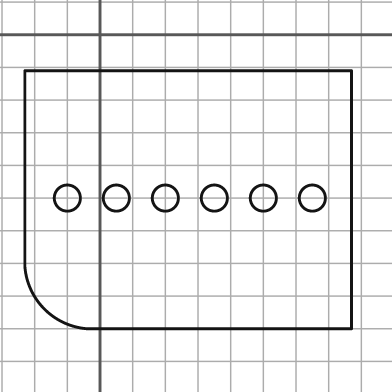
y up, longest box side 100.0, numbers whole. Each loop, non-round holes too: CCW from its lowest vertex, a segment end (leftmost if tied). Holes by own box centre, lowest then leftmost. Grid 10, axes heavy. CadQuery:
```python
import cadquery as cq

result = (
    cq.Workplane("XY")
    .moveTo(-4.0, -90.0)
    .lineTo(77.0, -90.0)
    .lineTo(77.0, -11.0)
    .lineTo(-23.0, -11.0)
    .lineTo(-23.0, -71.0)
    .threePointArc((-17.0, -84.0), (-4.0, -90.0))
    .close()
    .moveTo(-10.0, -50.0)
    .circle(4.0)
    .moveTo(5.0, -50.0)
    .circle(4.0)
    .moveTo(20.0, -50.0)
    .circle(4.0)
    .moveTo(35.0, -50.0)
    .circle(4.0)
    .moveTo(50.0, -50.0)
    .circle(4.0)
    .moveTo(65.0, -50.0)
    .circle(4.0)
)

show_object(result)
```